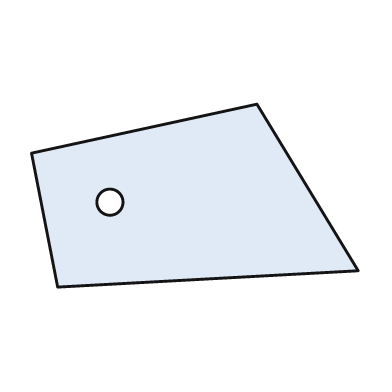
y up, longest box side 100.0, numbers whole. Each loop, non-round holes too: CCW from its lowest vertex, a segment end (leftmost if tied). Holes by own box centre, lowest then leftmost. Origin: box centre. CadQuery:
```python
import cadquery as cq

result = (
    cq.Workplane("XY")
    .moveTo(-42.0, -28.0)
    .lineTo(50.0, -23.0)
    .lineTo(19.0, 28.0)
    .lineTo(-50.0, 13.0)
    .close()
    .moveTo(-26.0, -2.0)
    .circle(4.0)
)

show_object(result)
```